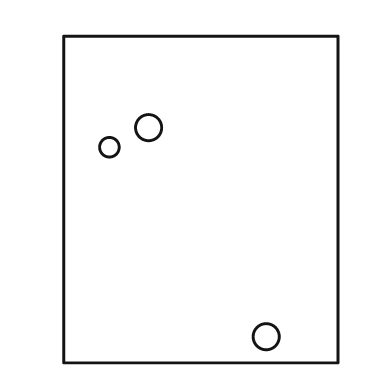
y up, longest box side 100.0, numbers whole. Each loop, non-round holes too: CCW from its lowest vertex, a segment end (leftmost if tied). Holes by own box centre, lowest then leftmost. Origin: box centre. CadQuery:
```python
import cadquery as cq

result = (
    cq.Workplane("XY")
    .moveTo(-42.0, -50.0)
    .lineTo(42.0, -50.0)
    .lineTo(42.0, 50.0)
    .lineTo(-42.0, 50.0)
    .close()
    .moveTo(20.0, -42.0)
    .circle(4.0)
    .moveTo(-28.0, 16.0)
    .circle(3.0)
    .moveTo(-16.0, 22.0)
    .circle(4.0)
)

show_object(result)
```